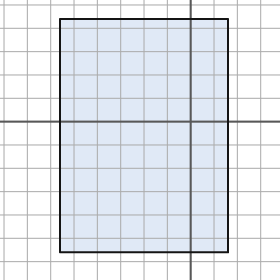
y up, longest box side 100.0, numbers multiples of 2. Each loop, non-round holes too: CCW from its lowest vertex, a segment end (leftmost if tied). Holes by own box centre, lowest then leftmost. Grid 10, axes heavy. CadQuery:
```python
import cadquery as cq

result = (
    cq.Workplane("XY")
    .moveTo(-56.0, -56.0)
    .lineTo(16.0, -56.0)
    .lineTo(16.0, 44.0)
    .lineTo(-56.0, 44.0)
    .close()
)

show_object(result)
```